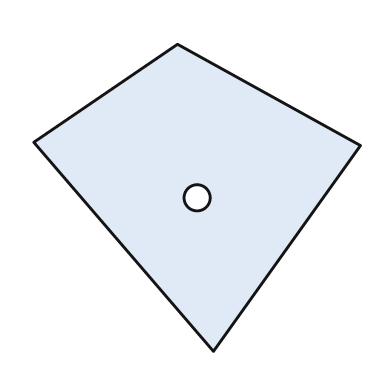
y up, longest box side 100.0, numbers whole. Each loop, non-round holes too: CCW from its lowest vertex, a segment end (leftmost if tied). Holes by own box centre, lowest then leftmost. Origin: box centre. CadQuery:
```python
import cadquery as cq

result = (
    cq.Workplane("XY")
    .moveTo(5.0, -47.0)
    .lineTo(50.0, 16.0)
    .lineTo(-6.0, 47.0)
    .lineTo(-50.0, 17.0)
    .close()
    .moveTo(0.0, 0.0)
    .circle(4.0)
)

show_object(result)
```